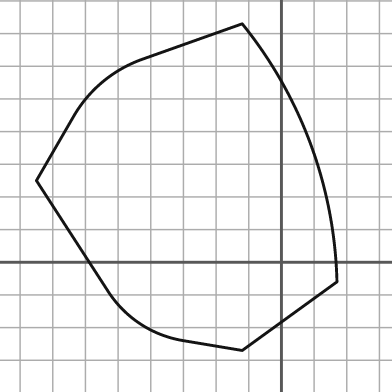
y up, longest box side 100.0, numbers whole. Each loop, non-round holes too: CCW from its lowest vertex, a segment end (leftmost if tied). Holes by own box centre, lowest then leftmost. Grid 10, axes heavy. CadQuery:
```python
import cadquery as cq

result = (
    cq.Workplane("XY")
    .moveTo(-12.0, -27.0)
    .lineTo(17.0, -6.0)
    .threePointArc((9.0, 36.0), (-12.0, 73.0))
    .lineTo(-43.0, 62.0)
    .threePointArc((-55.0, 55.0), (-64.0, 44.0))
    .lineTo(-75.0, 25.0)
    .lineTo(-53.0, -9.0)
    .threePointArc((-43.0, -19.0), (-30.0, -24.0))
    .close()
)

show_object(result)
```